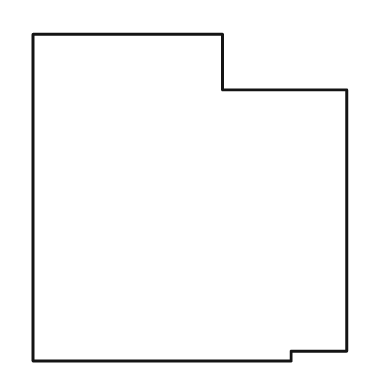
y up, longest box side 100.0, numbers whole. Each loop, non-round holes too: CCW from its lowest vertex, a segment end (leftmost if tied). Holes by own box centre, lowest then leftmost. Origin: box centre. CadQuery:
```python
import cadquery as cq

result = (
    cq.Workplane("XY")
    .moveTo(-48.0, -50.0)
    .lineTo(31.0, -50.0)
    .lineTo(31.0, -47.0)
    .lineTo(48.0, -47.0)
    .lineTo(48.0, 33.0)
    .lineTo(10.0, 33.0)
    .lineTo(10.0, 50.0)
    .lineTo(-48.0, 50.0)
    .close()
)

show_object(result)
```